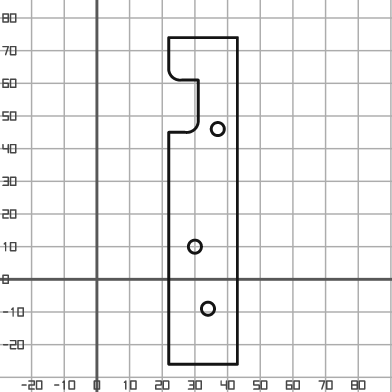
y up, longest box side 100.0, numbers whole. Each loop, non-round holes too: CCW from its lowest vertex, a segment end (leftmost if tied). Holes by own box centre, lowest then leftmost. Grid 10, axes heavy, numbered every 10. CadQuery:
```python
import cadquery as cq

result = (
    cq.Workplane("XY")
    .moveTo(22.0, -26.0)
    .lineTo(43.0, -26.0)
    .lineTo(43.0, 74.0)
    .lineTo(22.0, 74.0)
    .lineTo(22.0, 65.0)
    .threePointArc((23.0, 62.0), (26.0, 61.0))
    .lineTo(31.0, 61.0)
    .lineTo(31.0, 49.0)
    .threePointArc((30.0, 46.0), (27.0, 45.0))
    .lineTo(22.0, 45.0)
    .close()
    .moveTo(34.0, -9.0)
    .circle(2.0)
    .moveTo(30.0, 10.0)
    .circle(2.0)
    .moveTo(37.0, 46.0)
    .circle(2.0)
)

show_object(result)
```